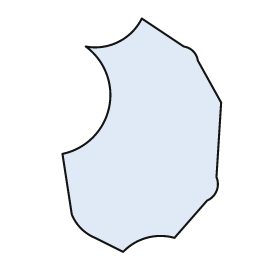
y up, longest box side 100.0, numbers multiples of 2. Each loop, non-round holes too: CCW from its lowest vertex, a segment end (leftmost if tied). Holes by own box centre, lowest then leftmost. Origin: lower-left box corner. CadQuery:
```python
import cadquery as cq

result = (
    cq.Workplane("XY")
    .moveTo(26.0, 0.0)
    .threePointArc((36.0, 6.0), (48.0, 6.0))
    .lineTo(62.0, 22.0)
    .threePointArc((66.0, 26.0), (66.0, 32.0))
    .lineTo(68.0, 64.0)
    .lineTo(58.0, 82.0)
    .threePointArc((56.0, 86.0), (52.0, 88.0))
    .lineTo(34.0, 100.0)
    .threePointArc((24.0, 90.0), (10.0, 88.0))
    .threePointArc((20.0, 62.0), (0.0, 42.0))
    .lineTo(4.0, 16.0)
    .threePointArc((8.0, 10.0), (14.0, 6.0))
    .close()
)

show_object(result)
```